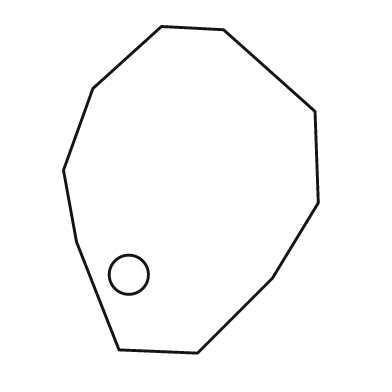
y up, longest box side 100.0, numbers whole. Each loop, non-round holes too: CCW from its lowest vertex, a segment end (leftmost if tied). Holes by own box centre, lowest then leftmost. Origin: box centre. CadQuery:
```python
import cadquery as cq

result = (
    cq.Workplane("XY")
    .moveTo(2.0, -50.0)
    .lineTo(25.0, -27.0)
    .lineTo(39.0, -4.0)
    .lineTo(38.0, 24.0)
    .lineTo(10.0, 49.0)
    .lineTo(-9.0, 50.0)
    .lineTo(-30.0, 31.0)
    .lineTo(-39.0, 6.0)
    .lineTo(-35.0, -16.0)
    .lineTo(-22.0, -49.0)
    .close()
    .moveTo(-19.0, -26.0)
    .circle(6.0)
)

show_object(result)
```